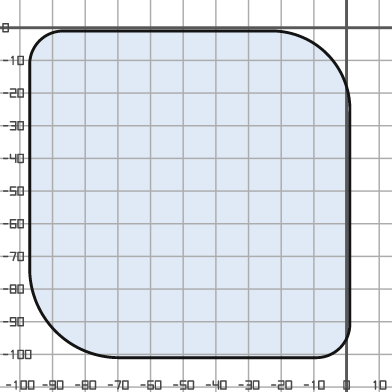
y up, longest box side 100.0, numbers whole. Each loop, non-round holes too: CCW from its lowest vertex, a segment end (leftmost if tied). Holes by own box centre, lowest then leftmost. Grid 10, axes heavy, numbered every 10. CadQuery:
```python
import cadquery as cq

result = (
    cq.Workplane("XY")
    .moveTo(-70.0, -101.0)
    .lineTo(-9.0, -101.0)
    .threePointArc((-2.0, -98.0), (1.0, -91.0))
    .lineTo(1.0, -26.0)
    .threePointArc((-6.0, -8.0), (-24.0, -1.0))
    .lineTo(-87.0, -1.0)
    .threePointArc((-94.0, -4.0), (-97.0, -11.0))
    .lineTo(-97.0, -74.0)
    .threePointArc((-89.0, -93.0), (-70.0, -101.0))
    .close()
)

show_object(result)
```